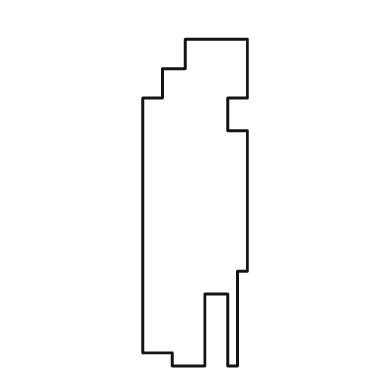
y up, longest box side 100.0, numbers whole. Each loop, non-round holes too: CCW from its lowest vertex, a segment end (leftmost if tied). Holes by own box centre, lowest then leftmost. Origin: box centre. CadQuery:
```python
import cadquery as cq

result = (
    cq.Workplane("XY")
    .moveTo(-7.0, -50.0)
    .lineTo(3.0, -50.0)
    .lineTo(3.0, -28.0)
    .lineTo(10.0, -28.0)
    .lineTo(10.0, -50.0)
    .lineTo(13.0, -50.0)
    .lineTo(13.0, -21.0)
    .lineTo(16.0, -21.0)
    .lineTo(16.0, 22.0)
    .lineTo(10.0, 22.0)
    .lineTo(10.0, 32.0)
    .lineTo(16.0, 32.0)
    .lineTo(16.0, 50.0)
    .lineTo(-3.0, 50.0)
    .lineTo(-3.0, 41.0)
    .lineTo(-10.0, 41.0)
    .lineTo(-10.0, 32.0)
    .lineTo(-16.0, 32.0)
    .lineTo(-16.0, -46.0)
    .lineTo(-7.0, -46.0)
    .close()
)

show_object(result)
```